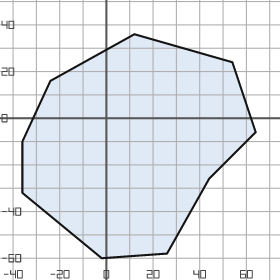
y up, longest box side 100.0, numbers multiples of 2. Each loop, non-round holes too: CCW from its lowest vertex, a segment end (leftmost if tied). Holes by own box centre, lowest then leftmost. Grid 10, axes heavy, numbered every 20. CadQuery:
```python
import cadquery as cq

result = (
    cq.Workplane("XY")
    .moveTo(-2.0, -60.0)
    .lineTo(26.0, -58.0)
    .lineTo(44.0, -26.0)
    .lineTo(64.0, -6.0)
    .lineTo(54.0, 24.0)
    .lineTo(12.0, 36.0)
    .lineTo(-24.0, 16.0)
    .lineTo(-36.0, -10.0)
    .lineTo(-36.0, -32.0)
    .close()
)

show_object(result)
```